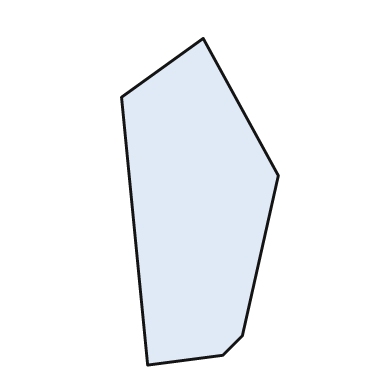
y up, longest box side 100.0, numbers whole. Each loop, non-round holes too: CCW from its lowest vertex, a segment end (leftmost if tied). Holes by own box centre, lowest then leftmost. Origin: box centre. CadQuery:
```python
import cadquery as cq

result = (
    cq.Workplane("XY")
    .moveTo(-16.0, -50.0)
    .lineTo(7.0, -47.0)
    .lineTo(13.0, -41.0)
    .lineTo(24.0, 8.0)
    .lineTo(1.0, 50.0)
    .lineTo(-24.0, 32.0)
    .close()
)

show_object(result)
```